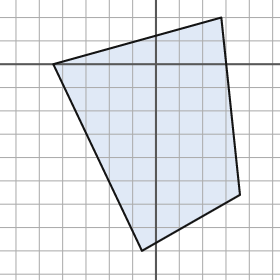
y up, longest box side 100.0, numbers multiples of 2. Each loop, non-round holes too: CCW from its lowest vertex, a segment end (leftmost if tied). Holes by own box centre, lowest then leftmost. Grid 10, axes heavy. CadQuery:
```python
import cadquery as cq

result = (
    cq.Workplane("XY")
    .moveTo(-6.0, -80.0)
    .lineTo(36.0, -56.0)
    .lineTo(28.0, 20.0)
    .lineTo(-44.0, 0.0)
    .close()
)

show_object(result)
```